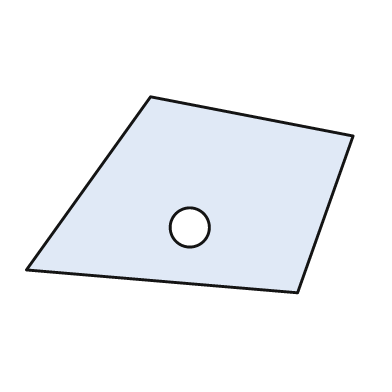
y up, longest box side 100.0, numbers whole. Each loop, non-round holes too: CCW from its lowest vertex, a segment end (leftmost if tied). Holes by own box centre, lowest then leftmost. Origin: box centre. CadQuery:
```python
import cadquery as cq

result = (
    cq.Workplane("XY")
    .moveTo(33.0, -30.0)
    .lineTo(50.0, 18.0)
    .lineTo(-12.0, 30.0)
    .lineTo(-50.0, -23.0)
    .close()
    .moveTo(0.0, -10.0)
    .circle(6.0)
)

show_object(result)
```